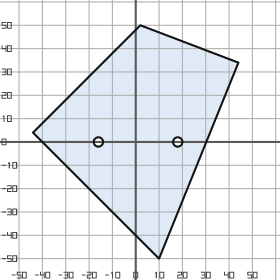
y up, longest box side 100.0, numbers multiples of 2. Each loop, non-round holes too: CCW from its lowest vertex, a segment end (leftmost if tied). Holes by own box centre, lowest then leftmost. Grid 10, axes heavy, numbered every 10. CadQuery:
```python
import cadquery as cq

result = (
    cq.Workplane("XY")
    .moveTo(10.0, -50.0)
    .lineTo(44.0, 34.0)
    .lineTo(2.0, 50.0)
    .lineTo(-44.0, 4.0)
    .close()
    .moveTo(-16.0, 0.0)
    .circle(2.0)
    .moveTo(18.0, 0.0)
    .circle(2.0)
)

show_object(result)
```